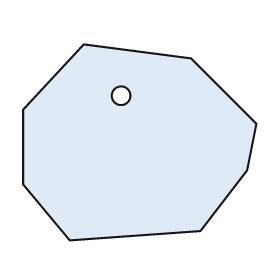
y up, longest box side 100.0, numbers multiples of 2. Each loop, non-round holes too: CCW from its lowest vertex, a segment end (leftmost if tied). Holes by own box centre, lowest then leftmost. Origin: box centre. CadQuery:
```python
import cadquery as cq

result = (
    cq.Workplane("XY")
    .moveTo(-30.0, -42.0)
    .lineTo(26.0, -38.0)
    .lineTo(46.0, -12.0)
    .lineTo(50.0, 8.0)
    .lineTo(22.0, 36.0)
    .lineTo(-24.0, 42.0)
    .lineTo(-50.0, 14.0)
    .lineTo(-50.0, -18.0)
    .close()
    .moveTo(-8.0, 20.0)
    .circle(4.0)
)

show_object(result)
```